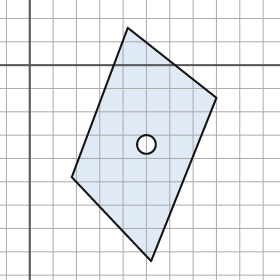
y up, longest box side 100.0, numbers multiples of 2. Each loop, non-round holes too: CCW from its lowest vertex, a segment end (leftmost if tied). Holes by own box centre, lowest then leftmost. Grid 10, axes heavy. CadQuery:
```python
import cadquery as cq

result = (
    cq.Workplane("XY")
    .moveTo(52.0, -84.0)
    .lineTo(80.0, -14.0)
    .lineTo(42.0, 16.0)
    .lineTo(18.0, -48.0)
    .close()
    .moveTo(50.0, -34.0)
    .circle(4.0)
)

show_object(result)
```